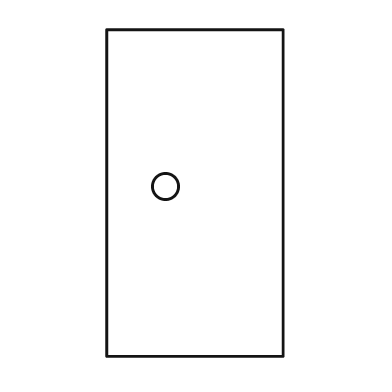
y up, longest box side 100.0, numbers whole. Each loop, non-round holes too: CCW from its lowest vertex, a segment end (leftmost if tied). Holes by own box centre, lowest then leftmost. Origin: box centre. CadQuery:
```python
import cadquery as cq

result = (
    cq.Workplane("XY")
    .moveTo(-27.0, -50.0)
    .lineTo(27.0, -50.0)
    .lineTo(27.0, 50.0)
    .lineTo(-27.0, 50.0)
    .close()
    .moveTo(-9.0, 2.0)
    .circle(4.0)
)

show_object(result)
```